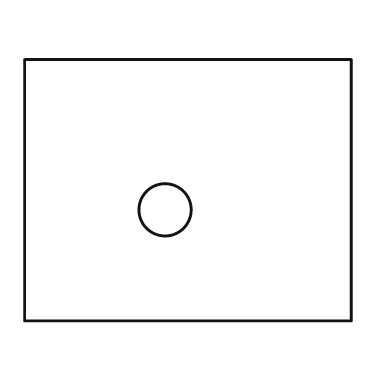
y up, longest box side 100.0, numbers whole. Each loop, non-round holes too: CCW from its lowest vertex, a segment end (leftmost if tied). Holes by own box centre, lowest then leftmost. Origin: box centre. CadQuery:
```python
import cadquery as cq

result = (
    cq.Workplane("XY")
    .moveTo(-50.0, -40.0)
    .lineTo(50.0, -40.0)
    .lineTo(50.0, 40.0)
    .lineTo(-50.0, 40.0)
    .close()
    .moveTo(-7.0, -6.0)
    .circle(8.0)
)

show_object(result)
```